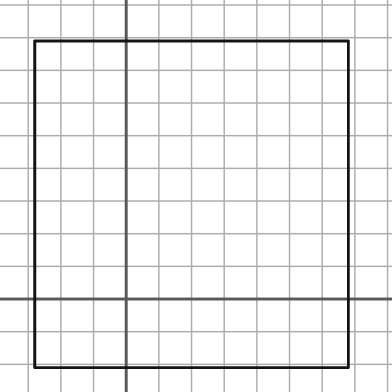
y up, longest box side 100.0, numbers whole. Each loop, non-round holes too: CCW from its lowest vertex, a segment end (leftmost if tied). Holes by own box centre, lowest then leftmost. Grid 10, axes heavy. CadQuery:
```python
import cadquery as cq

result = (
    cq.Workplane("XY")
    .moveTo(-28.0, -21.0)
    .lineTo(68.0, -21.0)
    .lineTo(68.0, 79.0)
    .lineTo(-28.0, 79.0)
    .close()
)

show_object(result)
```